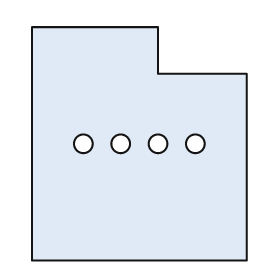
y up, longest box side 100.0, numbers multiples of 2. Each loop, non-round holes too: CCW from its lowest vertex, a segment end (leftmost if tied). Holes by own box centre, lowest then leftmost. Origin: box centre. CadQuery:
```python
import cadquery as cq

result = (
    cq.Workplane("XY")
    .moveTo(-46.0, -50.0)
    .lineTo(46.0, -50.0)
    .lineTo(46.0, 30.0)
    .lineTo(8.0, 30.0)
    .lineTo(8.0, 50.0)
    .lineTo(-46.0, 50.0)
    .close()
    .moveTo(-24.0, 0.0)
    .circle(4.0)
    .moveTo(-8.0, 0.0)
    .circle(4.0)
    .moveTo(8.0, 0.0)
    .circle(4.0)
    .moveTo(24.0, 0.0)
    .circle(4.0)
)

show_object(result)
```